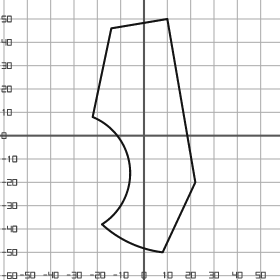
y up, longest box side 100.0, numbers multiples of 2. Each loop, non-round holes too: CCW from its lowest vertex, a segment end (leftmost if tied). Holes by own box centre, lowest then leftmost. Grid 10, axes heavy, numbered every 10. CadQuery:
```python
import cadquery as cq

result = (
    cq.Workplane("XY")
    .moveTo(8.0, -50.0)
    .lineTo(22.0, -20.0)
    .lineTo(10.0, 50.0)
    .lineTo(-14.0, 46.0)
    .lineTo(-22.0, 8.0)
    .threePointArc((-6.0, -14.0), (-18.0, -38.0))
    .threePointArc((-6.0, -46.0), (8.0, -50.0))
    .close()
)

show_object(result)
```